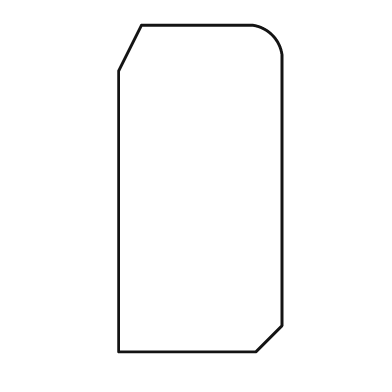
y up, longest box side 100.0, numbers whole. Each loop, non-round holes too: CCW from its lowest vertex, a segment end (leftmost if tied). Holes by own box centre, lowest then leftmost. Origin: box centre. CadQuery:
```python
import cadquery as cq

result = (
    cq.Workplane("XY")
    .moveTo(-25.0, -50.0)
    .lineTo(17.0, -50.0)
    .lineTo(25.0, -42.0)
    .lineTo(25.0, 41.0)
    .threePointArc((22.0, 47.0), (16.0, 50.0))
    .lineTo(-18.0, 50.0)
    .lineTo(-25.0, 36.0)
    .close()
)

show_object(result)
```